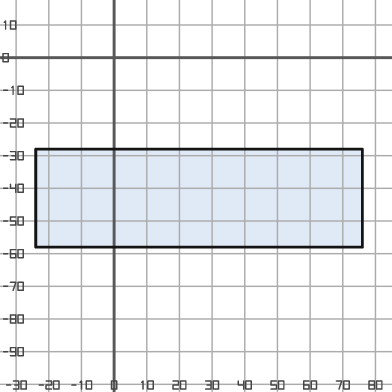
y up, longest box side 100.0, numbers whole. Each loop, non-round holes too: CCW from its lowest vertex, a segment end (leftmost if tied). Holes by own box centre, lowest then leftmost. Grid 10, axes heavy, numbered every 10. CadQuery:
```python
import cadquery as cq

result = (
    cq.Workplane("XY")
    .moveTo(-24.0, -58.0)
    .lineTo(76.0, -58.0)
    .lineTo(76.0, -28.0)
    .lineTo(-24.0, -28.0)
    .close()
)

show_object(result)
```